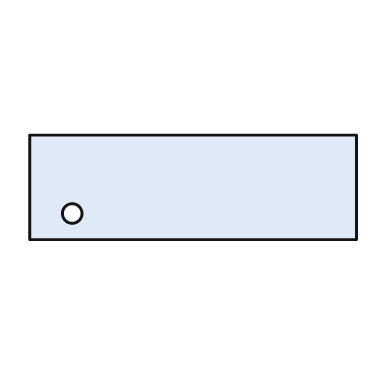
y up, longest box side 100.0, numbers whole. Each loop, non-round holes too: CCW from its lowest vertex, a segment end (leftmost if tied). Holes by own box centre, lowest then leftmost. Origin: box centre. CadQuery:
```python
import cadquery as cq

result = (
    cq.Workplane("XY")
    .moveTo(-50.0, -16.0)
    .lineTo(50.0, -16.0)
    .lineTo(50.0, 16.0)
    .lineTo(-50.0, 16.0)
    .close()
    .moveTo(-37.0, -8.0)
    .circle(3.0)
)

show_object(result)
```